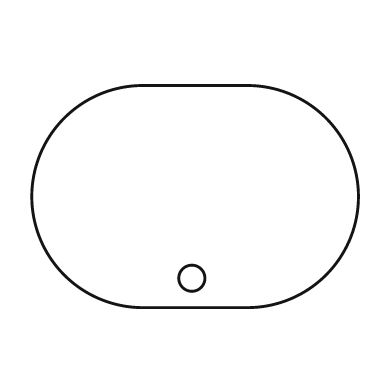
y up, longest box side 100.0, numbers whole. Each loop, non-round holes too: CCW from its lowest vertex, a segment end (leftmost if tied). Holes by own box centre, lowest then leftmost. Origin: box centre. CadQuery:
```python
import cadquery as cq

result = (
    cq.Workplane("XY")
    .moveTo(-16.0, -34.0)
    .lineTo(16.0, -34.0)
    .threePointArc((50.0, 0.0), (16.0, 34.0))
    .lineTo(-16.0, 34.0)
    .threePointArc((-50.0, 0.0), (-16.0, -34.0))
    .close()
    .moveTo(-1.0, -25.0)
    .circle(4.0)
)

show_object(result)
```